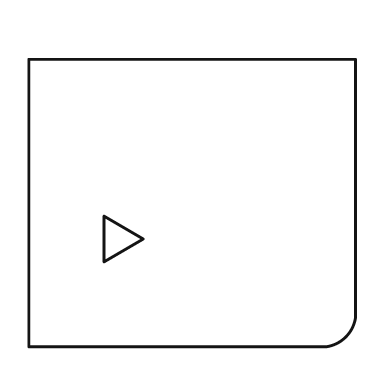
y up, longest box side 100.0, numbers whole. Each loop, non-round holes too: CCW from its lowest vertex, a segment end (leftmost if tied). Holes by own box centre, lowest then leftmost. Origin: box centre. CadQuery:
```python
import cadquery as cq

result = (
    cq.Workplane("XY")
    .moveTo(-50.0, -44.0)
    .lineTo(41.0, -44.0)
    .threePointArc((47.0, -41.0), (50.0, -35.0))
    .lineTo(50.0, 44.0)
    .lineTo(-50.0, 44.0)
    .close()
    .moveTo(-27.0, -18.0)
    .lineTo(-15.0, -11.0)
    .lineTo(-27.0, -4.0)
    .close()
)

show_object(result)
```